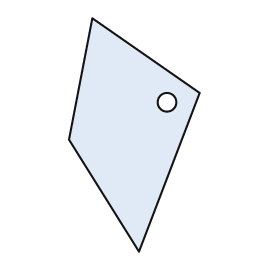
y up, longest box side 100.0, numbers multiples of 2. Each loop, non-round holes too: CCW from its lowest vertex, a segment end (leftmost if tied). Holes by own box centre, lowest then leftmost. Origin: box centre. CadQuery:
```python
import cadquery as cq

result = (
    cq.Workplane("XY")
    .moveTo(2.0, -50.0)
    .lineTo(28.0, 18.0)
    .lineTo(-18.0, 50.0)
    .lineTo(-28.0, -2.0)
    .close()
    .moveTo(14.0, 14.0)
    .circle(4.0)
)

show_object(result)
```